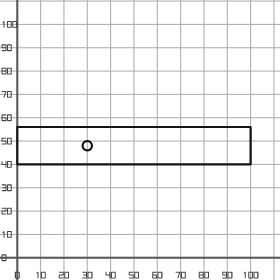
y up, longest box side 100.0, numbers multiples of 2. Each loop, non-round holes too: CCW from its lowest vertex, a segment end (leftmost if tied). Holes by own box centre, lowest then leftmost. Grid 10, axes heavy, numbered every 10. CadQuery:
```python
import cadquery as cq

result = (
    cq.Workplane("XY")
    .moveTo(0.0, 40.0)
    .lineTo(100.0, 40.0)
    .lineTo(100.0, 56.0)
    .lineTo(0.0, 56.0)
    .close()
    .moveTo(30.0, 48.0)
    .circle(2.0)
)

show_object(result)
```